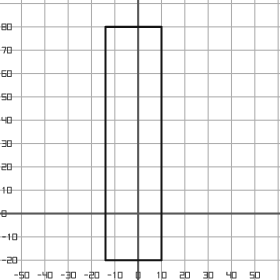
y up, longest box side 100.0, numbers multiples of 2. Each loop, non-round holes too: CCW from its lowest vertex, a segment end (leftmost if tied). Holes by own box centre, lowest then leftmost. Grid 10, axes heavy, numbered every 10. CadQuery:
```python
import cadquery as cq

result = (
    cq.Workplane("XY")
    .moveTo(-14.0, -20.0)
    .lineTo(10.0, -20.0)
    .lineTo(10.0, 80.0)
    .lineTo(-14.0, 80.0)
    .close()
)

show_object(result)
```